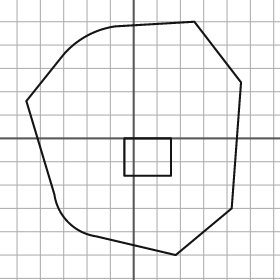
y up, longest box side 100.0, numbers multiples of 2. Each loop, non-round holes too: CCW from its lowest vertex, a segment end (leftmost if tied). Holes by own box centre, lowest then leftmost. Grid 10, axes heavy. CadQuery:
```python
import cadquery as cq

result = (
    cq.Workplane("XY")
    .moveTo(18.0, -50.0)
    .lineTo(42.0, -30.0)
    .lineTo(46.0, 24.0)
    .lineTo(26.0, 50.0)
    .lineTo(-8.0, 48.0)
    .threePointArc((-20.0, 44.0), (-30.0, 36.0))
    .lineTo(-46.0, 16.0)
    .lineTo(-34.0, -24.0)
    .threePointArc((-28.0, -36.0), (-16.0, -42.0))
    .close()
    .moveTo(-4.0, -16.0)
    .lineTo(16.0, -16.0)
    .lineTo(16.0, 0.0)
    .lineTo(-4.0, 0.0)
    .close()
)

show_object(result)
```